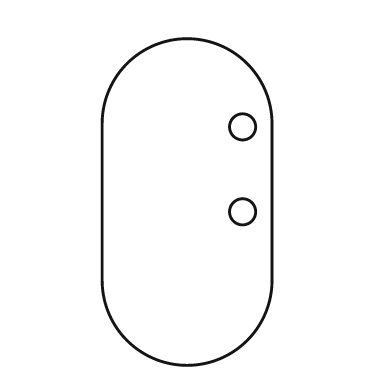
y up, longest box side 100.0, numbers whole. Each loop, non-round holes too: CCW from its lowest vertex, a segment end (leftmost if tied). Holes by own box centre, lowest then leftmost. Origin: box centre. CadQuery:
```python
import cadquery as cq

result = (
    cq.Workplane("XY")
    .moveTo(-26.0, -24.0)
    .threePointArc((0.0, -50.0), (26.0, -24.0))
    .lineTo(26.0, 24.0)
    .threePointArc((0.0, 50.0), (-26.0, 24.0))
    .close()
    .moveTo(17.0, -3.0)
    .circle(4.0)
    .moveTo(17.0, 23.0)
    .circle(4.0)
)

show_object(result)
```